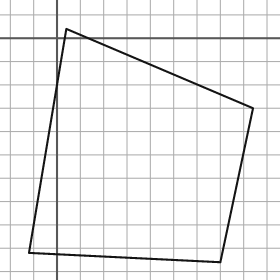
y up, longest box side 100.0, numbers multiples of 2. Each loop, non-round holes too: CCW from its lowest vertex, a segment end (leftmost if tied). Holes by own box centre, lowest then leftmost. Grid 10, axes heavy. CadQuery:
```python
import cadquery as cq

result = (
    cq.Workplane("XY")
    .moveTo(70.0, -96.0)
    .lineTo(84.0, -30.0)
    .lineTo(4.0, 4.0)
    .lineTo(-12.0, -92.0)
    .close()
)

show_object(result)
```